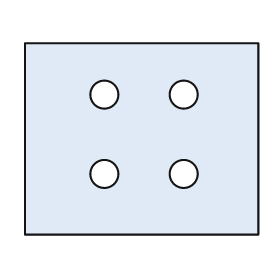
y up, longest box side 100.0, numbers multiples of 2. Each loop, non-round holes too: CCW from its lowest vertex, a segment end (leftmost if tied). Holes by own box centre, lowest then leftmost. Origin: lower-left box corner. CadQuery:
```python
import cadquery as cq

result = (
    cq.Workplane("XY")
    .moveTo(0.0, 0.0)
    .lineTo(100.0, 0.0)
    .lineTo(100.0, 82.0)
    .lineTo(0.0, 82.0)
    .close()
    .moveTo(34.0, 26.0)
    .circle(6.0)
    .moveTo(68.0, 26.0)
    .circle(6.0)
    .moveTo(34.0, 60.0)
    .circle(6.0)
    .moveTo(68.0, 60.0)
    .circle(6.0)
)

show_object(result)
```